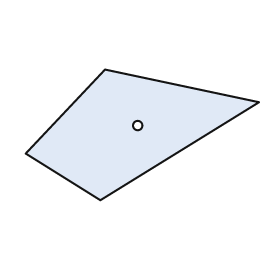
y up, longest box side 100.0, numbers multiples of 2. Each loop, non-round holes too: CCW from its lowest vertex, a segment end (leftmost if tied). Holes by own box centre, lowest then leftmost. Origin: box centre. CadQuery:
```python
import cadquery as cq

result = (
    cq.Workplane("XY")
    .moveTo(-18.0, -28.0)
    .lineTo(50.0, 14.0)
    .lineTo(-16.0, 28.0)
    .lineTo(-50.0, -8.0)
    .close()
    .moveTo(-2.0, 4.0)
    .circle(2.0)
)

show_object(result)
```